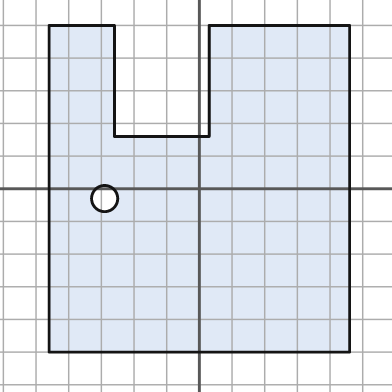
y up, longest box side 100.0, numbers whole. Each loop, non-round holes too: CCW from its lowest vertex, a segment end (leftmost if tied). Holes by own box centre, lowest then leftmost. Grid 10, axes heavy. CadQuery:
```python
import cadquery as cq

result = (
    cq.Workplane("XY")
    .moveTo(-46.0, -50.0)
    .lineTo(46.0, -50.0)
    .lineTo(46.0, 50.0)
    .lineTo(3.0, 50.0)
    .lineTo(3.0, 16.0)
    .lineTo(-26.0, 16.0)
    .lineTo(-26.0, 50.0)
    .lineTo(-46.0, 50.0)
    .close()
    .moveTo(-29.0, -3.0)
    .circle(4.0)
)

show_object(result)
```